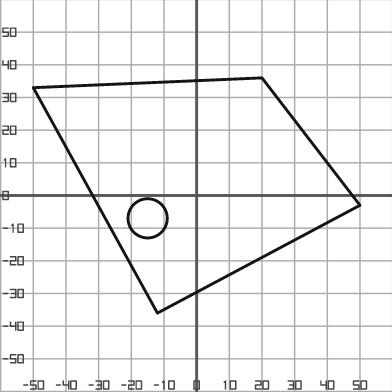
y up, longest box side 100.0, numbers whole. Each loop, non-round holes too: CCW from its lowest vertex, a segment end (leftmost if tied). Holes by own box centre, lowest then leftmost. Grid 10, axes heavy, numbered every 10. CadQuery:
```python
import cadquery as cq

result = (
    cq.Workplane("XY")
    .moveTo(-12.0, -36.0)
    .lineTo(50.0, -3.0)
    .lineTo(20.0, 36.0)
    .lineTo(-50.0, 33.0)
    .close()
    .moveTo(-15.0, -7.0)
    .circle(6.0)
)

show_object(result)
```